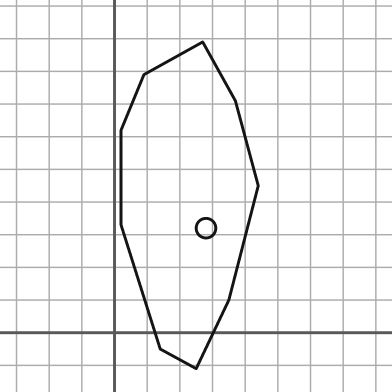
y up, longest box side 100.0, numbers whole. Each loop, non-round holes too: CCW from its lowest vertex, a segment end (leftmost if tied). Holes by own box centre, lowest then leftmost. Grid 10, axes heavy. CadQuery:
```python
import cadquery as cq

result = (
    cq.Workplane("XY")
    .moveTo(25.0, -11.0)
    .lineTo(35.0, 10.0)
    .lineTo(44.0, 45.0)
    .lineTo(37.0, 71.0)
    .lineTo(27.0, 89.0)
    .lineTo(9.0, 79.0)
    .lineTo(2.0, 62.0)
    .lineTo(2.0, 33.0)
    .lineTo(14.0, -5.0)
    .close()
    .moveTo(28.0, 32.0)
    .circle(3.0)
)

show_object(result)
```